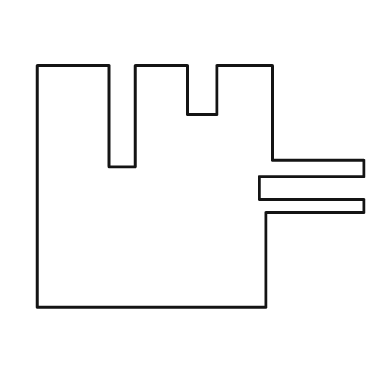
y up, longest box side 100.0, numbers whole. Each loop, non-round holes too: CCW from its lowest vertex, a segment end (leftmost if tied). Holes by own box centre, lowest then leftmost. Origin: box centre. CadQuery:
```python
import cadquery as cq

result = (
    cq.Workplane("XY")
    .moveTo(-50.0, -37.0)
    .lineTo(20.0, -37.0)
    .lineTo(20.0, -8.0)
    .lineTo(50.0, -8.0)
    .lineTo(50.0, -4.0)
    .lineTo(18.0, -4.0)
    .lineTo(18.0, 3.0)
    .lineTo(50.0, 3.0)
    .lineTo(50.0, 8.0)
    .lineTo(22.0, 8.0)
    .lineTo(22.0, 37.0)
    .lineTo(5.0, 37.0)
    .lineTo(5.0, 22.0)
    .lineTo(-4.0, 22.0)
    .lineTo(-4.0, 37.0)
    .lineTo(-20.0, 37.0)
    .lineTo(-20.0, 6.0)
    .lineTo(-28.0, 6.0)
    .lineTo(-28.0, 37.0)
    .lineTo(-50.0, 37.0)
    .close()
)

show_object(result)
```